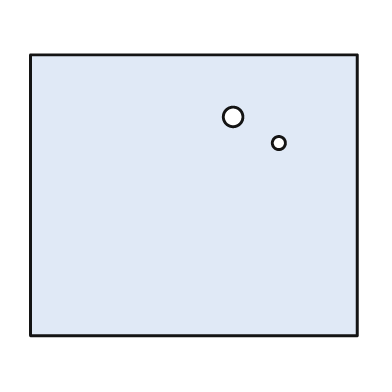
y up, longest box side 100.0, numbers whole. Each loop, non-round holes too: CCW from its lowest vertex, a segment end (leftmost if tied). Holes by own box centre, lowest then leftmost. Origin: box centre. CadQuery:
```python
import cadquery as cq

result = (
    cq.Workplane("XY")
    .moveTo(-50.0, -43.0)
    .lineTo(50.0, -43.0)
    .lineTo(50.0, 43.0)
    .lineTo(-50.0, 43.0)
    .close()
    .moveTo(26.0, 16.0)
    .circle(2.0)
    .moveTo(12.0, 24.0)
    .circle(3.0)
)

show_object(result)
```